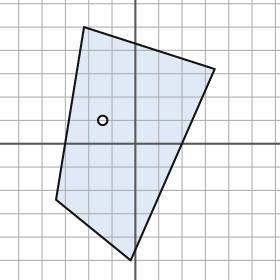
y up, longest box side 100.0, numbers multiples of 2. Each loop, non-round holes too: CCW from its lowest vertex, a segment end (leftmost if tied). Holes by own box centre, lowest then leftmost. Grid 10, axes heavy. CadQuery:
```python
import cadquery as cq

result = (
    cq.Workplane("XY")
    .moveTo(-2.0, -50.0)
    .lineTo(34.0, 32.0)
    .lineTo(-22.0, 50.0)
    .lineTo(-34.0, -24.0)
    .close()
    .moveTo(-14.0, 10.0)
    .circle(2.0)
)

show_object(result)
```